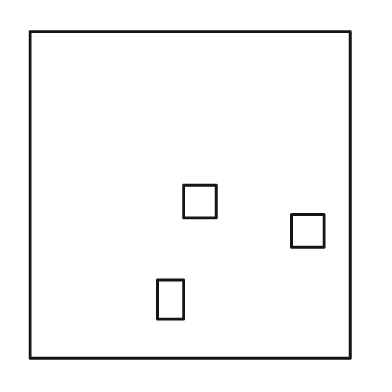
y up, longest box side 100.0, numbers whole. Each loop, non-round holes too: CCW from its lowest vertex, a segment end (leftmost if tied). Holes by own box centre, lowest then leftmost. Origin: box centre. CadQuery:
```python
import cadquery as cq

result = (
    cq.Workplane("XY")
    .moveTo(-49.0, -50.0)
    .lineTo(49.0, -50.0)
    .lineTo(49.0, 50.0)
    .lineTo(-49.0, 50.0)
    .close()
    .moveTo(-10.0, -38.0)
    .lineTo(-2.0, -38.0)
    .lineTo(-2.0, -26.0)
    .lineTo(-10.0, -26.0)
    .close()
    .moveTo(31.0, -16.0)
    .lineTo(41.0, -16.0)
    .lineTo(41.0, -6.0)
    .lineTo(31.0, -6.0)
    .close()
    .moveTo(-2.0, -7.0)
    .lineTo(8.0, -7.0)
    .lineTo(8.0, 3.0)
    .lineTo(-2.0, 3.0)
    .close()
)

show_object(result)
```